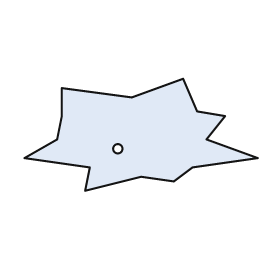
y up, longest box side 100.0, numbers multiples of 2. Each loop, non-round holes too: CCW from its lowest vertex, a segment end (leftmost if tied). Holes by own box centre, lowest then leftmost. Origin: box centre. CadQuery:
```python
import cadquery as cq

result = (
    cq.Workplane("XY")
    .moveTo(-24.0, -24.0)
    .lineTo(0.0, -18.0)
    .lineTo(14.0, -20.0)
    .lineTo(22.0, -14.0)
    .lineTo(50.0, -10.0)
    .lineTo(28.0, -2.0)
    .lineTo(36.0, 8.0)
    .lineTo(24.0, 10.0)
    .lineTo(18.0, 24.0)
    .lineTo(-4.0, 16.0)
    .lineTo(-34.0, 20.0)
    .lineTo(-34.0, 8.0)
    .lineTo(-36.0, -2.0)
    .lineTo(-50.0, -10.0)
    .lineTo(-22.0, -14.0)
    .close()
    .moveTo(-10.0, -6.0)
    .circle(2.0)
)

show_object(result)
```